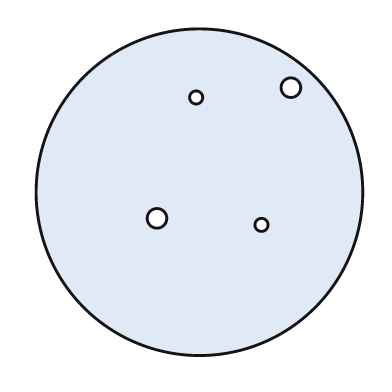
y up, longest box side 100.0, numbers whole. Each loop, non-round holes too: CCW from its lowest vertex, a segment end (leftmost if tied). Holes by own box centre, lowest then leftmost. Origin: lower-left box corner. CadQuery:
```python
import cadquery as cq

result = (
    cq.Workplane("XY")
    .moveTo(50.0, 50.0)
    .circle(50.0)
    .moveTo(69.0, 40.0)
    .circle(2.0)
    .moveTo(37.0, 42.0)
    .circle(3.0)
    .moveTo(49.0, 79.0)
    .circle(2.0)
    .moveTo(78.0, 82.0)
    .circle(3.0)
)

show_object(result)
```